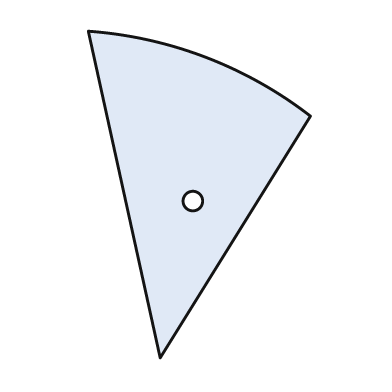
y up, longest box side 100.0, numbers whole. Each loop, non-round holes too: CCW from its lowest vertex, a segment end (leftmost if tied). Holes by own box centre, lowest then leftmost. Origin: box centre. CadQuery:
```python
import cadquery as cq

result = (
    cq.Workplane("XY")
    .moveTo(-12.0, -50.0)
    .lineTo(34.0, 24.0)
    .threePointArc((2.0, 42.0), (-34.0, 50.0))
    .close()
    .moveTo(-2.0, -2.0)
    .circle(3.0)
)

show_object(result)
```